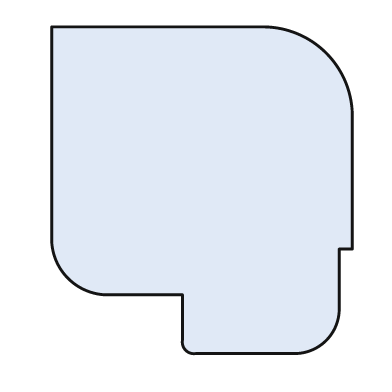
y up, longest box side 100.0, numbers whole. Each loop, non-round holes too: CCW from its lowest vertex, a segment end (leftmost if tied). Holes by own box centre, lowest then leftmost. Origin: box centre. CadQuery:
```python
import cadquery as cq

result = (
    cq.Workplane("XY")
    .moveTo(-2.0, -50.0)
    .lineTo(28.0, -50.0)
    .threePointArc((38.0, -46.0), (42.0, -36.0))
    .lineTo(42.0, -18.0)
    .lineTo(46.0, -18.0)
    .lineTo(46.0, 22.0)
    .threePointArc((38.0, 42.0), (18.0, 50.0))
    .lineTo(-46.0, 50.0)
    .lineTo(-46.0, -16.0)
    .threePointArc((-41.0, -27.0), (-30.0, -32.0))
    .lineTo(-6.0, -32.0)
    .lineTo(-6.0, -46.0)
    .threePointArc((-5.0, -49.0), (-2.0, -50.0))
    .close()
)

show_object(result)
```